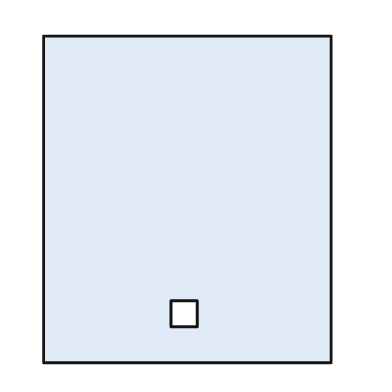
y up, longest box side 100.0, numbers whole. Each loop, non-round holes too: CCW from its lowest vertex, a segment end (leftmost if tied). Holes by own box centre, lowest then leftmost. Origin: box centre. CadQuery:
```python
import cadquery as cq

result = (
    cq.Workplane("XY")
    .moveTo(-44.0, -50.0)
    .lineTo(44.0, -50.0)
    .lineTo(44.0, 50.0)
    .lineTo(-44.0, 50.0)
    .close()
    .moveTo(-5.0, -39.0)
    .lineTo(3.0, -39.0)
    .lineTo(3.0, -31.0)
    .lineTo(-5.0, -31.0)
    .close()
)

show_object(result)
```